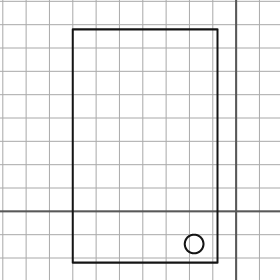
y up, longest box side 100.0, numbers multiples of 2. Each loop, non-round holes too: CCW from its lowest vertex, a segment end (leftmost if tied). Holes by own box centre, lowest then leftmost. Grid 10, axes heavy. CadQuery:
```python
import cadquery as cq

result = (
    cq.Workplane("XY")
    .moveTo(-70.0, -22.0)
    .lineTo(-8.0, -22.0)
    .lineTo(-8.0, 78.0)
    .lineTo(-70.0, 78.0)
    .close()
    .moveTo(-18.0, -14.0)
    .circle(4.0)
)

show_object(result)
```